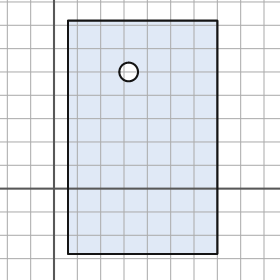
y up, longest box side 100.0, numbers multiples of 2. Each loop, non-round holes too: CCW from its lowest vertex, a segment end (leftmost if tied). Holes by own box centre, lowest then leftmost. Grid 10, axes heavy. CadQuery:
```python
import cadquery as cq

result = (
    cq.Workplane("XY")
    .moveTo(6.0, -28.0)
    .lineTo(70.0, -28.0)
    .lineTo(70.0, 72.0)
    .lineTo(6.0, 72.0)
    .close()
    .moveTo(32.0, 50.0)
    .circle(4.0)
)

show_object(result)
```